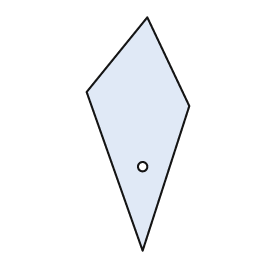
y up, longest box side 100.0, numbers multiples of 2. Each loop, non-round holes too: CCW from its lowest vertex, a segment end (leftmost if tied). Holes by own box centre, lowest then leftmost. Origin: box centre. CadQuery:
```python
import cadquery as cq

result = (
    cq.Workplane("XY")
    .moveTo(2.0, -50.0)
    .lineTo(22.0, 12.0)
    .lineTo(4.0, 50.0)
    .lineTo(-22.0, 18.0)
    .close()
    .moveTo(2.0, -14.0)
    .circle(2.0)
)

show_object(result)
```